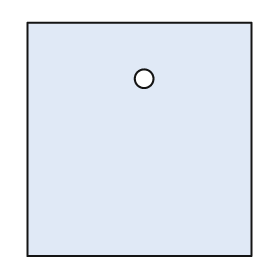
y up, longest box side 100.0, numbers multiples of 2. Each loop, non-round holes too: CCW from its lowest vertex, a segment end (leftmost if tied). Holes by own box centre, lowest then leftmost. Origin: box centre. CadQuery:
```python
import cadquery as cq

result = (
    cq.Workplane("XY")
    .moveTo(-48.0, -50.0)
    .lineTo(48.0, -50.0)
    .lineTo(48.0, 50.0)
    .lineTo(-48.0, 50.0)
    .close()
    .moveTo(2.0, 26.0)
    .circle(4.0)
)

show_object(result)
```